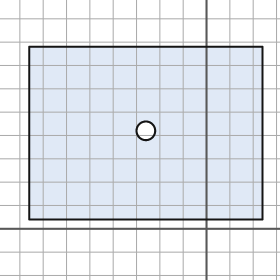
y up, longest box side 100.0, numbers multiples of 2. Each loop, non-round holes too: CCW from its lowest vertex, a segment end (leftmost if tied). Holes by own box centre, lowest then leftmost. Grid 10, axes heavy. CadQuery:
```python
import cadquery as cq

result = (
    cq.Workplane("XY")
    .moveTo(-76.0, 4.0)
    .lineTo(24.0, 4.0)
    .lineTo(24.0, 78.0)
    .lineTo(-76.0, 78.0)
    .close()
    .moveTo(-26.0, 42.0)
    .circle(4.0)
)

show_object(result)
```